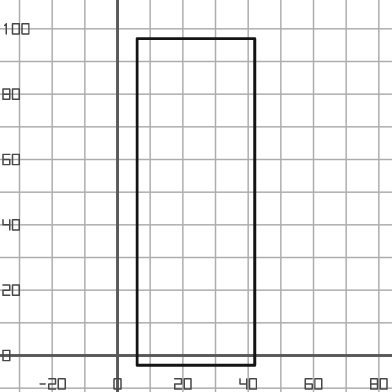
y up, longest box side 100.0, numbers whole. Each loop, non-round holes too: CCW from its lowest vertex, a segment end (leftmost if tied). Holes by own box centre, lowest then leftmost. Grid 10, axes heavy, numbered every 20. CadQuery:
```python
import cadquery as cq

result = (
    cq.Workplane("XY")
    .moveTo(6.0, -3.0)
    .lineTo(42.0, -3.0)
    .lineTo(42.0, 97.0)
    .lineTo(6.0, 97.0)
    .close()
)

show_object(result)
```